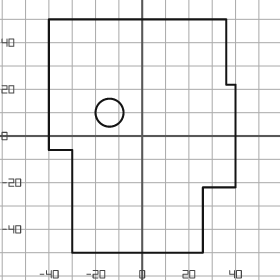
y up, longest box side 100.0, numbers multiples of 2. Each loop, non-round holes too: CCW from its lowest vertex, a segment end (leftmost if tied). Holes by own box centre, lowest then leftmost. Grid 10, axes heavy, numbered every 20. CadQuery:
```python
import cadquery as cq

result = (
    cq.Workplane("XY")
    .moveTo(-30.0, -50.0)
    .lineTo(26.0, -50.0)
    .lineTo(26.0, -22.0)
    .lineTo(40.0, -22.0)
    .lineTo(40.0, 22.0)
    .lineTo(36.0, 22.0)
    .lineTo(36.0, 50.0)
    .lineTo(-40.0, 50.0)
    .lineTo(-40.0, -6.0)
    .lineTo(-30.0, -6.0)
    .close()
    .moveTo(-14.0, 10.0)
    .circle(6.0)
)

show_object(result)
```